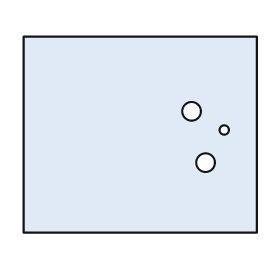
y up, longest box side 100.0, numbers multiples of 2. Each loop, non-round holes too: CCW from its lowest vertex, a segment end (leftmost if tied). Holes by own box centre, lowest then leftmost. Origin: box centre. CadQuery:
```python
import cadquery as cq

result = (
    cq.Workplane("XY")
    .moveTo(-50.0, -42.0)
    .lineTo(50.0, -42.0)
    .lineTo(50.0, 42.0)
    .lineTo(-50.0, 42.0)
    .close()
    .moveTo(28.0, -12.0)
    .circle(4.0)
    .moveTo(36.0, 2.0)
    .circle(2.0)
    .moveTo(22.0, 10.0)
    .circle(4.0)
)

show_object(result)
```